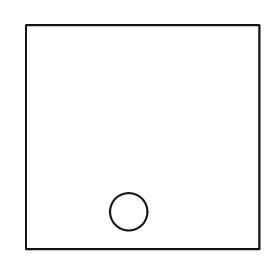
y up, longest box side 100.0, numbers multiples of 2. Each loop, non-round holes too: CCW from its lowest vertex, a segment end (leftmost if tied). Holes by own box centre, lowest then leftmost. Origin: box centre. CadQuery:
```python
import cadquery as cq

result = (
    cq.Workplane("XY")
    .moveTo(-50.0, -48.0)
    .lineTo(50.0, -48.0)
    .lineTo(50.0, 48.0)
    .lineTo(-50.0, 48.0)
    .close()
    .moveTo(-6.0, -32.0)
    .circle(8.0)
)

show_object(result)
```